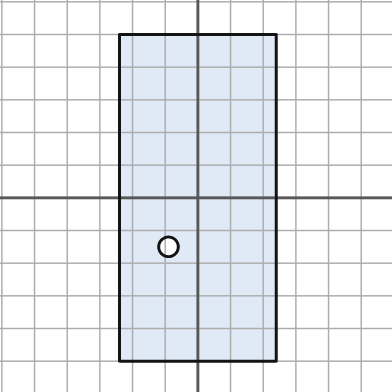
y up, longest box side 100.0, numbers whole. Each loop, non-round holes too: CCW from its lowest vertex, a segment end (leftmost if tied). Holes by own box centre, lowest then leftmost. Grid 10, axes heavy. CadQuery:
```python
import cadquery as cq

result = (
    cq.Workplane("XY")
    .moveTo(-24.0, -50.0)
    .lineTo(24.0, -50.0)
    .lineTo(24.0, 50.0)
    .lineTo(-24.0, 50.0)
    .close()
    .moveTo(-9.0, -15.0)
    .circle(3.0)
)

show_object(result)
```